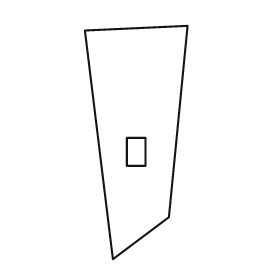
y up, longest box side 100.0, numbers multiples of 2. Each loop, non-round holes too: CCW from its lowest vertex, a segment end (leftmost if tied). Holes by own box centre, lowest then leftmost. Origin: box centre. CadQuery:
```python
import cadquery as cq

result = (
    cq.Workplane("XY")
    .moveTo(-10.0, -50.0)
    .lineTo(14.0, -32.0)
    .lineTo(22.0, 50.0)
    .lineTo(-22.0, 48.0)
    .close()
    .moveTo(-4.0, -10.0)
    .lineTo(4.0, -10.0)
    .lineTo(4.0, 2.0)
    .lineTo(-4.0, 2.0)
    .close()
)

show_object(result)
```